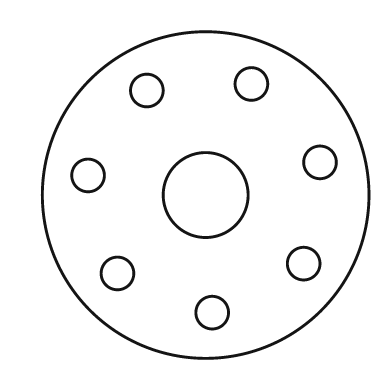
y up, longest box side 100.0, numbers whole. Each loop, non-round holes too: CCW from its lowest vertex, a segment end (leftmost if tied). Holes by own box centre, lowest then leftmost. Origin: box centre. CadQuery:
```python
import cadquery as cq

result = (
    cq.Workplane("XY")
    .moveTo(0.0, 0.0)
    .circle(50.0)
    .moveTo(2.0, -36.0)
    .circle(5.0)
    .moveTo(-27.0, -24.0)
    .circle(5.0)
    .moveTo(30.0, -21.0)
    .circle(5.0)
    .moveTo(0.0, 0.0)
    .circle(13.0)
    .moveTo(-36.0, 6.0)
    .circle(5.0)
    .moveTo(35.0, 10.0)
    .circle(5.0)
    .moveTo(-18.0, 32.0)
    .circle(5.0)
    .moveTo(14.0, 34.0)
    .circle(5.0)
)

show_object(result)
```